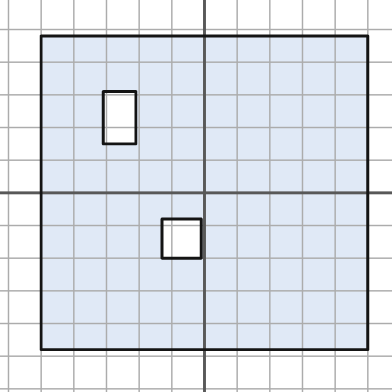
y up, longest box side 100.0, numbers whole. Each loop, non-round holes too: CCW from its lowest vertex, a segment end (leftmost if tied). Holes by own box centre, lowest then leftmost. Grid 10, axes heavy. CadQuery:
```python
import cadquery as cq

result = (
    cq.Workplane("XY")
    .moveTo(-50.0, -48.0)
    .lineTo(50.0, -48.0)
    .lineTo(50.0, 48.0)
    .lineTo(-50.0, 48.0)
    .close()
    .moveTo(-13.0, -20.0)
    .lineTo(-1.0, -20.0)
    .lineTo(-1.0, -8.0)
    .lineTo(-13.0, -8.0)
    .close()
    .moveTo(-31.0, 15.0)
    .lineTo(-21.0, 15.0)
    .lineTo(-21.0, 31.0)
    .lineTo(-31.0, 31.0)
    .close()
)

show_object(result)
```